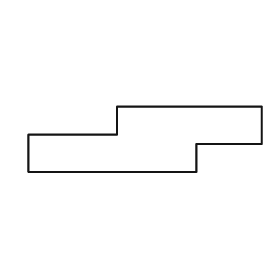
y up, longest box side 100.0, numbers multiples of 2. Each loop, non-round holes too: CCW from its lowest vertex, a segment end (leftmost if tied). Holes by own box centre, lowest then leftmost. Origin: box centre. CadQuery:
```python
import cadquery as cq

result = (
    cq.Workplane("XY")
    .moveTo(-50.0, -14.0)
    .lineTo(22.0, -14.0)
    .lineTo(22.0, -2.0)
    .lineTo(50.0, -2.0)
    .lineTo(50.0, 14.0)
    .lineTo(-12.0, 14.0)
    .lineTo(-12.0, 2.0)
    .lineTo(-50.0, 2.0)
    .close()
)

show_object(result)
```